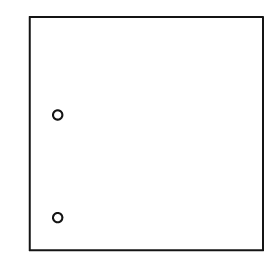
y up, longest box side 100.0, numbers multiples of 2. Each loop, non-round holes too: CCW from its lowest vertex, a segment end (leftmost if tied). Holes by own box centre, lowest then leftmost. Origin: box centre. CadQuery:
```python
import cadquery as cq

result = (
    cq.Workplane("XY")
    .moveTo(-50.0, -50.0)
    .lineTo(50.0, -50.0)
    .lineTo(50.0, 50.0)
    .lineTo(-50.0, 50.0)
    .close()
    .moveTo(-38.0, -36.0)
    .circle(2.0)
    .moveTo(-38.0, 8.0)
    .circle(2.0)
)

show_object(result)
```